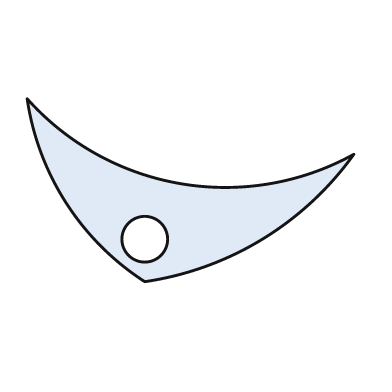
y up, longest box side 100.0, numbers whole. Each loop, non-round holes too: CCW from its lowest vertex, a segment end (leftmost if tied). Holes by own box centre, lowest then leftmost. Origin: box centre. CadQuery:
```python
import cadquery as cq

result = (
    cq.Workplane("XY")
    .moveTo(-14.0, -28.0)
    .threePointArc((22.0, -15.0), (50.0, 11.0))
    .threePointArc((-3.0, 2.0), (-50.0, 28.0))
    .threePointArc((-38.0, -4.0), (-14.0, -28.0))
    .close()
    .moveTo(-14.0, -15.0)
    .circle(7.0)
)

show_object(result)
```